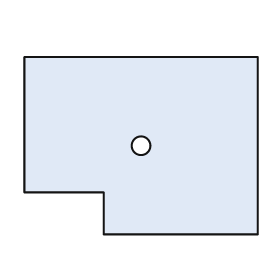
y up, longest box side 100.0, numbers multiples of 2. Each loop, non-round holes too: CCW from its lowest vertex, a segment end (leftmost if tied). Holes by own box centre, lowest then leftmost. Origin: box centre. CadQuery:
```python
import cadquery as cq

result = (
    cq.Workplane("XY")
    .moveTo(-16.0, -38.0)
    .lineTo(50.0, -38.0)
    .lineTo(50.0, 38.0)
    .lineTo(-50.0, 38.0)
    .lineTo(-50.0, -20.0)
    .lineTo(-16.0, -20.0)
    .close()
    .moveTo(0.0, 0.0)
    .circle(4.0)
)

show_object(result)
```